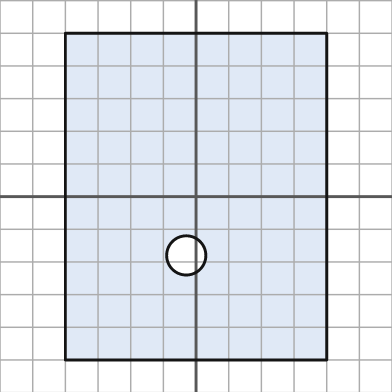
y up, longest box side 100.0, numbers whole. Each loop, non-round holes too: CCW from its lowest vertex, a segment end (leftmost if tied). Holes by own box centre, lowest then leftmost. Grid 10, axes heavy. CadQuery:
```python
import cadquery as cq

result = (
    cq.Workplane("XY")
    .moveTo(-40.0, -50.0)
    .lineTo(40.0, -50.0)
    .lineTo(40.0, 50.0)
    .lineTo(-40.0, 50.0)
    .close()
    .moveTo(-3.0, -18.0)
    .circle(6.0)
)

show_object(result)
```